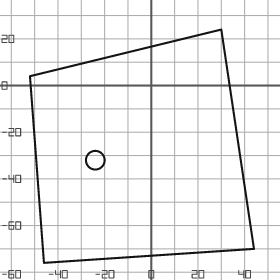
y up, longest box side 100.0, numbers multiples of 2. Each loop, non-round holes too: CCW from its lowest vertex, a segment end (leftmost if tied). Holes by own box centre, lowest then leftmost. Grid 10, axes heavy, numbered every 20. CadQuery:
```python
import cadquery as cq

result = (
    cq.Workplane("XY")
    .moveTo(-46.0, -76.0)
    .lineTo(44.0, -70.0)
    .lineTo(30.0, 24.0)
    .lineTo(-52.0, 4.0)
    .close()
    .moveTo(-24.0, -32.0)
    .circle(4.0)
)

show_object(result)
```